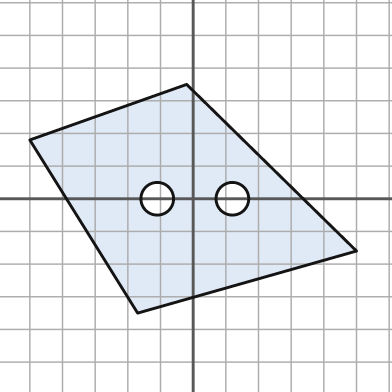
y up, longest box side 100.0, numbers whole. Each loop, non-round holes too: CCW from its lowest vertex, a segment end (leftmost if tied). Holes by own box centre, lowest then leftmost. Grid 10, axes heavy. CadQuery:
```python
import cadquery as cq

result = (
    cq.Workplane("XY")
    .moveTo(-17.0, -35.0)
    .lineTo(50.0, -16.0)
    .lineTo(-2.0, 35.0)
    .lineTo(-50.0, 18.0)
    .close()
    .moveTo(-11.0, 0.0)
    .circle(5.0)
    .moveTo(12.0, 0.0)
    .circle(5.0)
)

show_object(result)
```